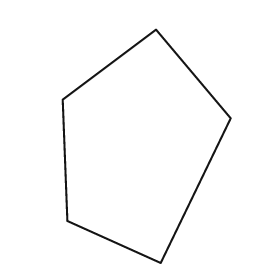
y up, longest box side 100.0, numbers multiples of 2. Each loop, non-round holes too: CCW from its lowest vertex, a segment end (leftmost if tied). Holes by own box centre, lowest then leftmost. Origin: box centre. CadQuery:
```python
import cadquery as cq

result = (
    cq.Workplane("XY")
    .moveTo(6.0, -50.0)
    .lineTo(36.0, 12.0)
    .lineTo(4.0, 50.0)
    .lineTo(-36.0, 20.0)
    .lineTo(-34.0, -32.0)
    .close()
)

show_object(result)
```